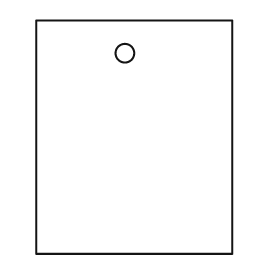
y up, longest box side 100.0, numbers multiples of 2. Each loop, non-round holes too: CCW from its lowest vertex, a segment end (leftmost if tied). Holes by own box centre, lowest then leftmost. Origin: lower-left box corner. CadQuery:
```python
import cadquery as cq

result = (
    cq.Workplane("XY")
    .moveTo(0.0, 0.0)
    .lineTo(84.0, 0.0)
    .lineTo(84.0, 100.0)
    .lineTo(0.0, 100.0)
    .close()
    .moveTo(38.0, 86.0)
    .circle(4.0)
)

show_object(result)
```